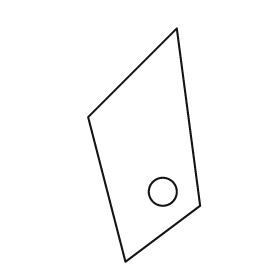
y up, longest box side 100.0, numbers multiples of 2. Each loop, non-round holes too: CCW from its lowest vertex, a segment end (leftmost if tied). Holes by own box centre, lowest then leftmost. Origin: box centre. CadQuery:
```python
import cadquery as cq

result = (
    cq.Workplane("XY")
    .moveTo(-8.0, -50.0)
    .lineTo(24.0, -26.0)
    .lineTo(14.0, 50.0)
    .lineTo(-24.0, 12.0)
    .close()
    .moveTo(8.0, -20.0)
    .circle(6.0)
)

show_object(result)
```